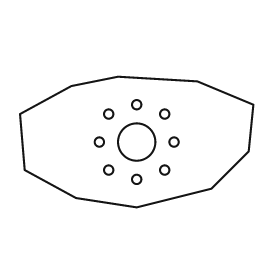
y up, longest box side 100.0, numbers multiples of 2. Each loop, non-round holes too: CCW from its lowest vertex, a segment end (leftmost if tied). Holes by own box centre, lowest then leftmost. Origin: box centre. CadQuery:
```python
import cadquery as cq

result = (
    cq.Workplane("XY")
    .moveTo(0.0, -28.0)
    .lineTo(32.0, -20.0)
    .lineTo(48.0, -4.0)
    .lineTo(50.0, 16.0)
    .lineTo(26.0, 26.0)
    .lineTo(-8.0, 28.0)
    .lineTo(-28.0, 24.0)
    .lineTo(-50.0, 12.0)
    .lineTo(-48.0, -12.0)
    .lineTo(-26.0, -24.0)
    .close()
    .moveTo(0.0, -16.0)
    .circle(2.0)
    .moveTo(-12.0, -12.0)
    .circle(2.0)
    .moveTo(12.0, -12.0)
    .circle(2.0)
    .moveTo(-16.0, 0.0)
    .circle(2.0)
    .moveTo(0.0, 0.0)
    .circle(8.0)
    .moveTo(16.0, 0.0)
    .circle(2.0)
    .moveTo(-12.0, 12.0)
    .circle(2.0)
    .moveTo(12.0, 12.0)
    .circle(2.0)
    .moveTo(0.0, 16.0)
    .circle(2.0)
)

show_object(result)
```